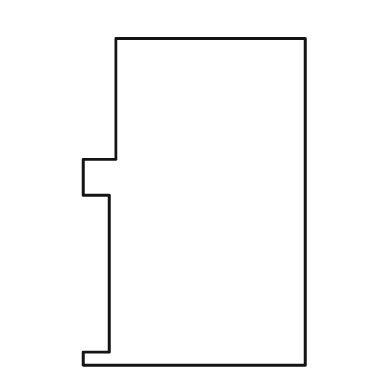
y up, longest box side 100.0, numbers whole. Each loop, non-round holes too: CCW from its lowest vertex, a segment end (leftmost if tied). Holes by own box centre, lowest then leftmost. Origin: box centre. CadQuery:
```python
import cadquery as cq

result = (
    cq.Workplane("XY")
    .moveTo(-34.0, -50.0)
    .lineTo(34.0, -50.0)
    .lineTo(34.0, 50.0)
    .lineTo(-24.0, 50.0)
    .lineTo(-24.0, 13.0)
    .lineTo(-34.0, 13.0)
    .lineTo(-34.0, 2.0)
    .lineTo(-26.0, 2.0)
    .lineTo(-26.0, -46.0)
    .lineTo(-34.0, -46.0)
    .close()
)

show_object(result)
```